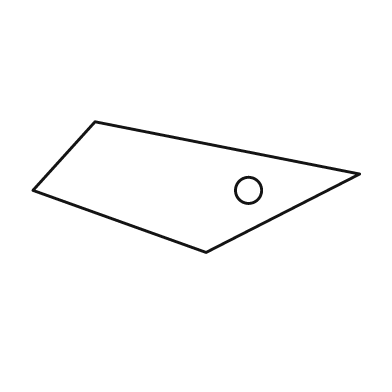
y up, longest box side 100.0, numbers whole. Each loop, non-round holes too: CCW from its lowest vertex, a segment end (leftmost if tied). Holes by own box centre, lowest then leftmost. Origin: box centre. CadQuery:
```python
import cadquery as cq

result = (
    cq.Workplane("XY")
    .moveTo(3.0, -20.0)
    .lineTo(50.0, 4.0)
    .lineTo(-31.0, 20.0)
    .lineTo(-50.0, -1.0)
    .close()
    .moveTo(16.0, -1.0)
    .circle(4.0)
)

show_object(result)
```